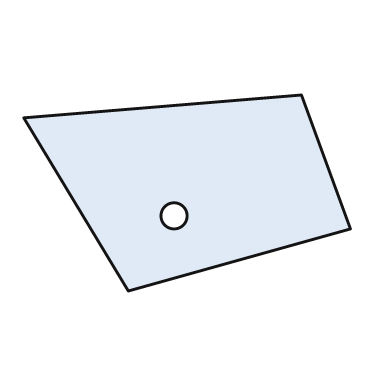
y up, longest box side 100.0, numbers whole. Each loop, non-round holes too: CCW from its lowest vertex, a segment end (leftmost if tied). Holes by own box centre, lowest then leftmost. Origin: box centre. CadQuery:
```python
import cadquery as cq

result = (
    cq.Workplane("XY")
    .moveTo(-18.0, -30.0)
    .lineTo(50.0, -11.0)
    .lineTo(35.0, 30.0)
    .lineTo(-50.0, 23.0)
    .close()
    .moveTo(-4.0, -7.0)
    .circle(4.0)
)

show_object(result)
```